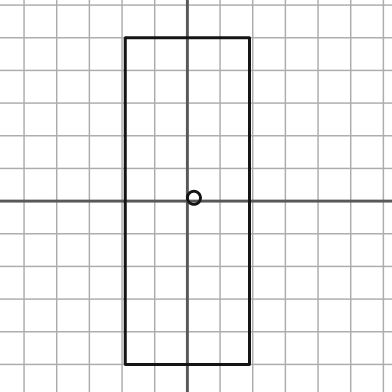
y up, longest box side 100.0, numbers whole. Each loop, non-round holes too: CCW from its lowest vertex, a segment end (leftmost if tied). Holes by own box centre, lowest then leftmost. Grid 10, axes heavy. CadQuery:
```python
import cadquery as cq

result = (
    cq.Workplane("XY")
    .moveTo(-19.0, -50.0)
    .lineTo(19.0, -50.0)
    .lineTo(19.0, 50.0)
    .lineTo(-19.0, 50.0)
    .close()
    .moveTo(2.0, 1.0)
    .circle(2.0)
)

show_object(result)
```